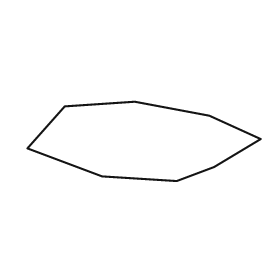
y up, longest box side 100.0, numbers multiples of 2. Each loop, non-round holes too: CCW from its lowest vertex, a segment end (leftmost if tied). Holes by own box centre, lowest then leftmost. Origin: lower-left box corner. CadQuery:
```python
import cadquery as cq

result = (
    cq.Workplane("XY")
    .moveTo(64.0, 0.0)
    .lineTo(80.0, 6.0)
    .lineTo(100.0, 18.0)
    .lineTo(78.0, 28.0)
    .lineTo(46.0, 34.0)
    .lineTo(16.0, 32.0)
    .lineTo(0.0, 14.0)
    .lineTo(32.0, 2.0)
    .close()
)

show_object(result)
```